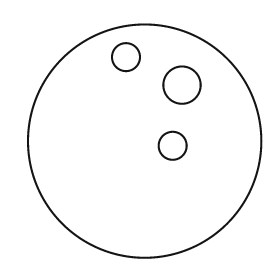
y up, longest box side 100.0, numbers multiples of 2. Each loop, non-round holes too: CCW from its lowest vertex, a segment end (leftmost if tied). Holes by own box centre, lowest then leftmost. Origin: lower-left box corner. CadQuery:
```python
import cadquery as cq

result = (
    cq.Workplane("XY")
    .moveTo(50.0, 50.0)
    .circle(50.0)
    .moveTo(62.0, 48.0)
    .circle(6.0)
    .moveTo(66.0, 74.0)
    .circle(8.0)
    .moveTo(42.0, 86.0)
    .circle(6.0)
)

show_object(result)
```